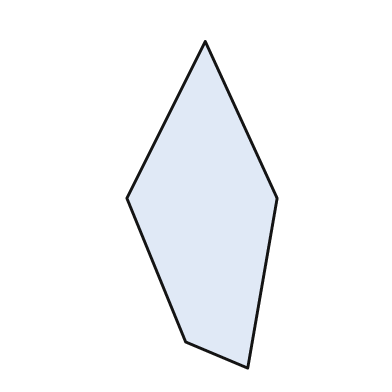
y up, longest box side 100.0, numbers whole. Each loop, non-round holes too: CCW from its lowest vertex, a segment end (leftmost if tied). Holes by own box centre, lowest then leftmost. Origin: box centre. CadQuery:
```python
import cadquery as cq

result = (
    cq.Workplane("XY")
    .moveTo(14.0, -50.0)
    .lineTo(23.0, 2.0)
    .lineTo(1.0, 50.0)
    .lineTo(-23.0, 2.0)
    .lineTo(-5.0, -42.0)
    .close()
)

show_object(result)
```